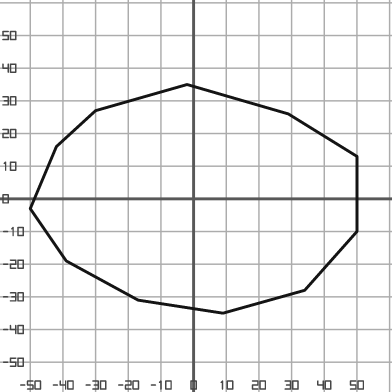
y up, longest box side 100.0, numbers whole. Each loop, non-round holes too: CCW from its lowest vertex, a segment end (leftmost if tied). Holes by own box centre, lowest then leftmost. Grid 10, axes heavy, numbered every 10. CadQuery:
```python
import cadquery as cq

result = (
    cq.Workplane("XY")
    .moveTo(9.0, -35.0)
    .lineTo(34.0, -28.0)
    .lineTo(50.0, -10.0)
    .lineTo(50.0, 13.0)
    .lineTo(29.0, 26.0)
    .lineTo(-2.0, 35.0)
    .lineTo(-30.0, 27.0)
    .lineTo(-42.0, 16.0)
    .lineTo(-50.0, -3.0)
    .lineTo(-39.0, -19.0)
    .lineTo(-17.0, -31.0)
    .close()
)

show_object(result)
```